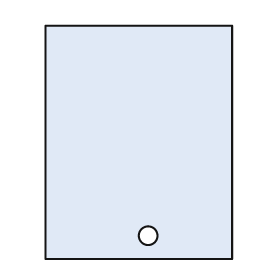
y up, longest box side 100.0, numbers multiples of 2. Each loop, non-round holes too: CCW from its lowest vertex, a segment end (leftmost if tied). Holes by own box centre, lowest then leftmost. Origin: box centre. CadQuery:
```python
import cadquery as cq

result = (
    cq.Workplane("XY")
    .moveTo(-40.0, -50.0)
    .lineTo(40.0, -50.0)
    .lineTo(40.0, 50.0)
    .lineTo(-40.0, 50.0)
    .close()
    .moveTo(4.0, -40.0)
    .circle(4.0)
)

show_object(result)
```